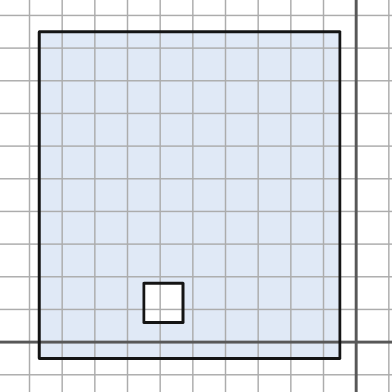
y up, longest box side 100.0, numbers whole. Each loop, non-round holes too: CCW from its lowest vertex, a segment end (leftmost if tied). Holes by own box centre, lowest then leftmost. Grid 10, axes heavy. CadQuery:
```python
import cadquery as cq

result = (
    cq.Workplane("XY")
    .moveTo(-97.0, -5.0)
    .lineTo(-5.0, -5.0)
    .lineTo(-5.0, 95.0)
    .lineTo(-97.0, 95.0)
    .close()
    .moveTo(-65.0, 6.0)
    .lineTo(-53.0, 6.0)
    .lineTo(-53.0, 18.0)
    .lineTo(-65.0, 18.0)
    .close()
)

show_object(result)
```